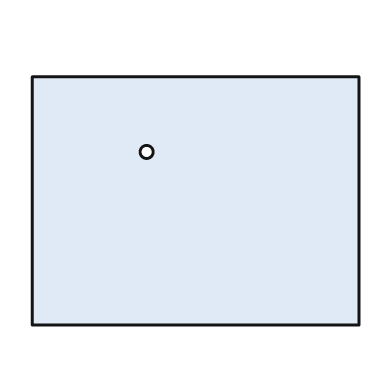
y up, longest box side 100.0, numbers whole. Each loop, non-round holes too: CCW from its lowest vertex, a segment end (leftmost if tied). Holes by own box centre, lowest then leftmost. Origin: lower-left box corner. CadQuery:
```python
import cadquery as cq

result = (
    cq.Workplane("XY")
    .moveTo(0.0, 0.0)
    .lineTo(100.0, 0.0)
    .lineTo(100.0, 76.0)
    .lineTo(0.0, 76.0)
    .close()
    .moveTo(35.0, 53.0)
    .circle(2.0)
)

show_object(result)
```